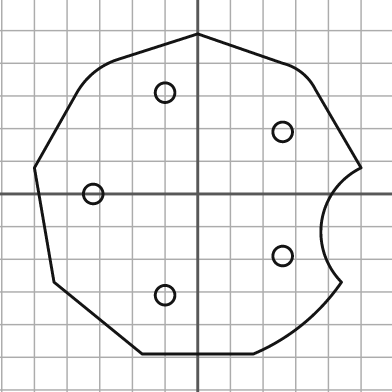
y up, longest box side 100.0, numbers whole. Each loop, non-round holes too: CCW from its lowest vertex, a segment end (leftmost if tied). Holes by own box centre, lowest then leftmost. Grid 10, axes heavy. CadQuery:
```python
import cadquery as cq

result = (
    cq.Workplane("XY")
    .moveTo(-17.0, -49.0)
    .lineTo(17.0, -49.0)
    .threePointArc((32.0, -40.0), (44.0, -27.0))
    .threePointArc((38.0, -8.0), (50.0, 8.0))
    .lineTo(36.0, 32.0)
    .threePointArc((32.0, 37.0), (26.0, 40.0))
    .lineTo(0.0, 49.0)
    .lineTo(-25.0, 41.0)
    .threePointArc((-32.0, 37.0), (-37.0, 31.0))
    .lineTo(-50.0, 8.0)
    .lineTo(-44.0, -27.0)
    .close()
    .moveTo(-10.0, -31.0)
    .circle(3.0)
    .moveTo(26.0, -19.0)
    .circle(3.0)
    .moveTo(-32.0, 0.0)
    .circle(3.0)
    .moveTo(26.0, 19.0)
    .circle(3.0)
    .moveTo(-10.0, 31.0)
    .circle(3.0)
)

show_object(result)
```